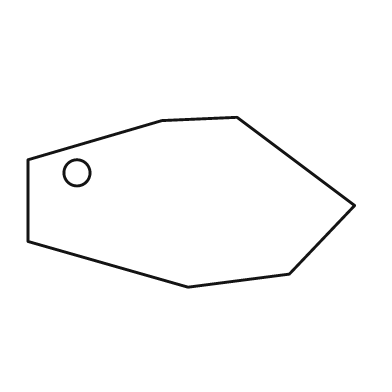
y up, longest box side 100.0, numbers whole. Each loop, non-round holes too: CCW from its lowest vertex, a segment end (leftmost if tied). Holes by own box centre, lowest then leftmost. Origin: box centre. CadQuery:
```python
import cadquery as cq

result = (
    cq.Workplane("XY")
    .moveTo(-1.0, -26.0)
    .lineTo(30.0, -22.0)
    .lineTo(50.0, -1.0)
    .lineTo(14.0, 26.0)
    .lineTo(-9.0, 25.0)
    .lineTo(-50.0, 13.0)
    .lineTo(-50.0, -12.0)
    .close()
    .moveTo(-35.0, 9.0)
    .circle(4.0)
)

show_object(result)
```